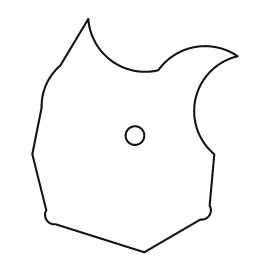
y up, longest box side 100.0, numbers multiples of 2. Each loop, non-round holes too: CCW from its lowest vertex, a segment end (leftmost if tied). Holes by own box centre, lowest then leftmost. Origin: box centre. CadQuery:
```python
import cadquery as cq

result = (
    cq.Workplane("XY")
    .moveTo(4.0, -50.0)
    .lineTo(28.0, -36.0)
    .threePointArc((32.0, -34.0), (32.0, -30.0))
    .lineTo(34.0, -8.0)
    .threePointArc((26.0, 16.0), (44.0, 34.0))
    .threePointArc((26.0, 38.0), (10.0, 28.0))
    .threePointArc((-10.0, 32.0), (-20.0, 50.0))
    .lineTo(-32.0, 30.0)
    .threePointArc((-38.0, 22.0), (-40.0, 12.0))
    .lineTo(-44.0, -8.0)
    .lineTo(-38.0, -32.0)
    .threePointArc((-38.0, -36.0), (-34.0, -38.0))
    .close()
    .moveTo(0.0, 0.0)
    .circle(4.0)
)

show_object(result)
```